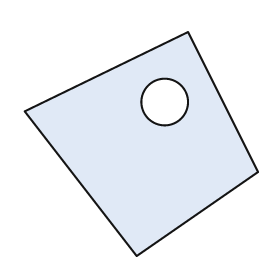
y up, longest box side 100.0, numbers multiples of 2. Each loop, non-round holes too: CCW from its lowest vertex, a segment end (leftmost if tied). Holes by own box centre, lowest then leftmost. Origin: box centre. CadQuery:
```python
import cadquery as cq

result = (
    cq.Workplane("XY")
    .moveTo(-2.0, -48.0)
    .lineTo(50.0, -12.0)
    .lineTo(20.0, 48.0)
    .lineTo(-50.0, 14.0)
    .close()
    .moveTo(10.0, 18.0)
    .circle(10.0)
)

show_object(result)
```